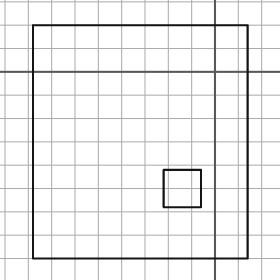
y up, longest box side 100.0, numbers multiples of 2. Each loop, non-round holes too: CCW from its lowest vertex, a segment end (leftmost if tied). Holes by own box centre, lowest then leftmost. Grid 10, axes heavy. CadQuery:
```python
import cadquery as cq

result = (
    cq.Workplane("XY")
    .moveTo(-78.0, -80.0)
    .lineTo(14.0, -80.0)
    .lineTo(14.0, 20.0)
    .lineTo(-78.0, 20.0)
    .close()
    .moveTo(-22.0, -58.0)
    .lineTo(-6.0, -58.0)
    .lineTo(-6.0, -42.0)
    .lineTo(-22.0, -42.0)
    .close()
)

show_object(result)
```